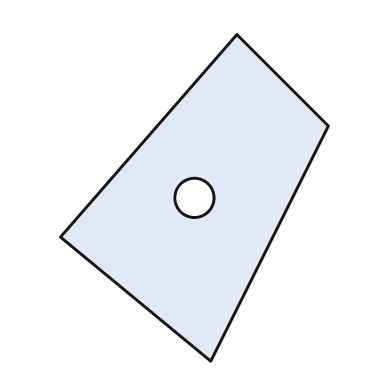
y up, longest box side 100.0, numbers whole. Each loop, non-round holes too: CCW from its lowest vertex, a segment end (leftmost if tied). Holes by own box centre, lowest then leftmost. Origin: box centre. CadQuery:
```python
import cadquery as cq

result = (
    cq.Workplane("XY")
    .moveTo(5.0, -50.0)
    .lineTo(41.0, 22.0)
    .lineTo(13.0, 50.0)
    .lineTo(-41.0, -12.0)
    .close()
    .moveTo(0.0, 0.0)
    .circle(6.0)
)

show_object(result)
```